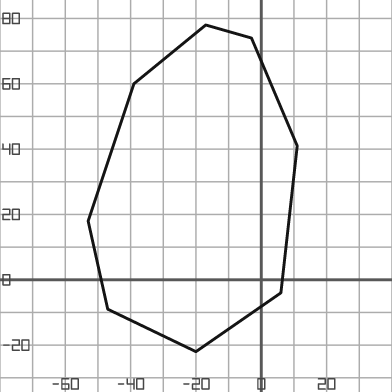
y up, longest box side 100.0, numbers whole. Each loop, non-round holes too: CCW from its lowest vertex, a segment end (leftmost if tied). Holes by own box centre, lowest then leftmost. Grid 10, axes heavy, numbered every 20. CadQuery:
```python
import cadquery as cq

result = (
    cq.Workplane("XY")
    .moveTo(-20.0, -22.0)
    .lineTo(6.0, -4.0)
    .lineTo(11.0, 41.0)
    .lineTo(-3.0, 74.0)
    .lineTo(-17.0, 78.0)
    .lineTo(-39.0, 60.0)
    .lineTo(-53.0, 18.0)
    .lineTo(-47.0, -9.0)
    .close()
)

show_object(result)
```